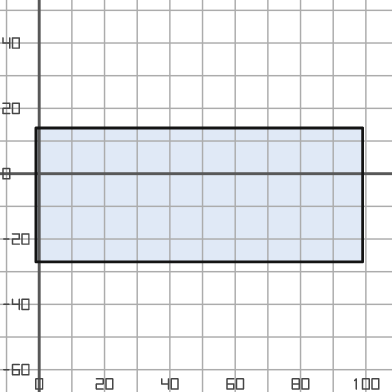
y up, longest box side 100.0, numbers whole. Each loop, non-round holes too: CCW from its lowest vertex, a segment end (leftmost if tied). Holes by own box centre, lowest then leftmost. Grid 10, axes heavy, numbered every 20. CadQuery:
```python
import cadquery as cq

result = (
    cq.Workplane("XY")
    .moveTo(-1.0, -27.0)
    .lineTo(99.0, -27.0)
    .lineTo(99.0, 14.0)
    .lineTo(-1.0, 14.0)
    .close()
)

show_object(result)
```